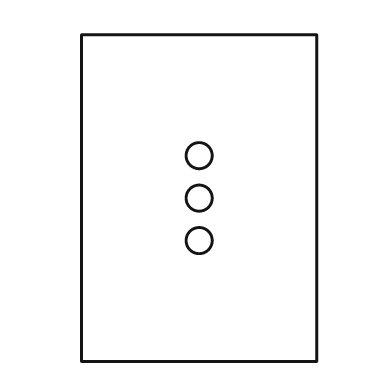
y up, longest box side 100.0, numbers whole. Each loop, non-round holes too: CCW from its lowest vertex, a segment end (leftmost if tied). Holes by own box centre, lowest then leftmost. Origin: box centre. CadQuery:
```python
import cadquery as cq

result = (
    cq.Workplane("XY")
    .moveTo(-36.0, -50.0)
    .lineTo(36.0, -50.0)
    .lineTo(36.0, 50.0)
    .lineTo(-36.0, 50.0)
    .close()
    .moveTo(0.0, -13.0)
    .circle(4.0)
    .moveTo(0.0, 0.0)
    .circle(4.0)
    .moveTo(0.0, 13.0)
    .circle(4.0)
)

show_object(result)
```